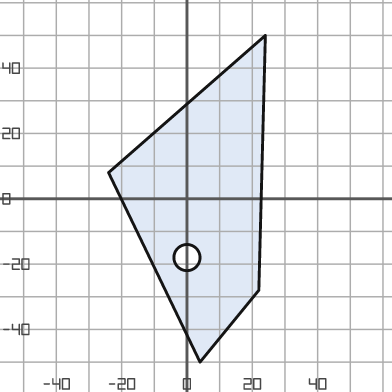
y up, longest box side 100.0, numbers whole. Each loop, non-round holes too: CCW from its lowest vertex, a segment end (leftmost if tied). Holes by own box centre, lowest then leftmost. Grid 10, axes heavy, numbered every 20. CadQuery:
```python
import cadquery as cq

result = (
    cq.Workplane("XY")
    .moveTo(4.0, -50.0)
    .lineTo(22.0, -28.0)
    .lineTo(24.0, 50.0)
    .lineTo(-24.0, 8.0)
    .close()
    .moveTo(0.0, -18.0)
    .circle(4.0)
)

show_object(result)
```